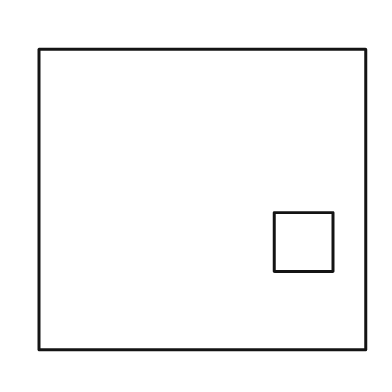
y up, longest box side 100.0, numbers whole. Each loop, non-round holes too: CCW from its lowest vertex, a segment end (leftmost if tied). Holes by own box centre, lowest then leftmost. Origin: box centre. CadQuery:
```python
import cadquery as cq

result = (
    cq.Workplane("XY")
    .moveTo(-50.0, -46.0)
    .lineTo(50.0, -46.0)
    .lineTo(50.0, 46.0)
    .lineTo(-50.0, 46.0)
    .close()
    .moveTo(22.0, -22.0)
    .lineTo(40.0, -22.0)
    .lineTo(40.0, -4.0)
    .lineTo(22.0, -4.0)
    .close()
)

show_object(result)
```